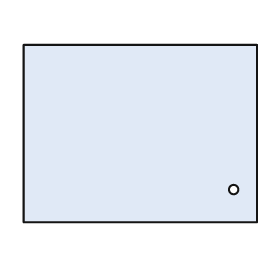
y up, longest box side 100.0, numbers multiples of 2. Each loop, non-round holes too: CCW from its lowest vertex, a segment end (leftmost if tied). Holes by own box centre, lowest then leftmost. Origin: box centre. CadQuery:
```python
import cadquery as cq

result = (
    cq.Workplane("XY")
    .moveTo(-50.0, -38.0)
    .lineTo(50.0, -38.0)
    .lineTo(50.0, 38.0)
    .lineTo(-50.0, 38.0)
    .close()
    .moveTo(40.0, -24.0)
    .circle(2.0)
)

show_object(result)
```